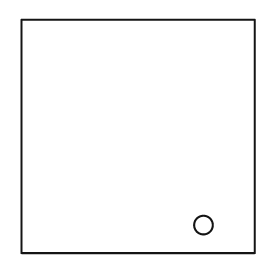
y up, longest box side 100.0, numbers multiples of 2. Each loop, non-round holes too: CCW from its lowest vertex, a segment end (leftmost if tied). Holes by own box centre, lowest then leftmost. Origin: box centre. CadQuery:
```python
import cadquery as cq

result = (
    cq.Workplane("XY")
    .moveTo(-50.0, -50.0)
    .lineTo(50.0, -50.0)
    .lineTo(50.0, 50.0)
    .lineTo(-50.0, 50.0)
    .close()
    .moveTo(28.0, -38.0)
    .circle(4.0)
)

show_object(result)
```